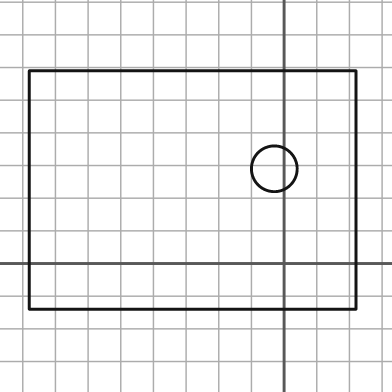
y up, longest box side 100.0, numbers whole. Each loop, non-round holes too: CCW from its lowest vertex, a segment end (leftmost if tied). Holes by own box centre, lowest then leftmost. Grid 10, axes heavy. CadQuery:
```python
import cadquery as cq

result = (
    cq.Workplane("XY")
    .moveTo(-78.0, -14.0)
    .lineTo(22.0, -14.0)
    .lineTo(22.0, 59.0)
    .lineTo(-78.0, 59.0)
    .close()
    .moveTo(-3.0, 29.0)
    .circle(7.0)
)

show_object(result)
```